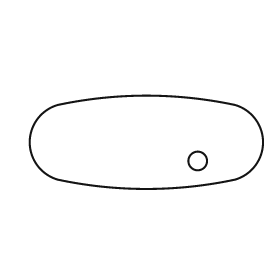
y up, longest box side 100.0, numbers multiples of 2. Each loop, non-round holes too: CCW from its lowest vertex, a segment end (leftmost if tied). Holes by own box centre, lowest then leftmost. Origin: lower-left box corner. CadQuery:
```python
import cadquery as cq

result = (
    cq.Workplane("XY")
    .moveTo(12.0, 4.0)
    .threePointArc((50.0, 0.0), (88.0, 4.0))
    .threePointArc((100.0, 20.0), (88.0, 36.0))
    .threePointArc((50.0, 40.0), (12.0, 36.0))
    .threePointArc((0.0, 20.0), (12.0, 4.0))
    .close()
    .moveTo(72.0, 12.0)
    .circle(4.0)
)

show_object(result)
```